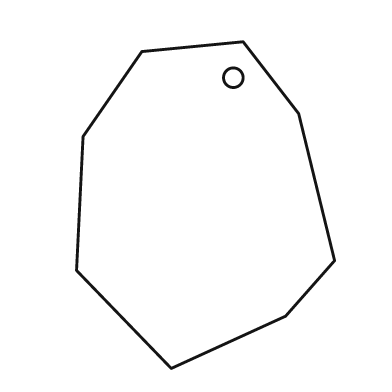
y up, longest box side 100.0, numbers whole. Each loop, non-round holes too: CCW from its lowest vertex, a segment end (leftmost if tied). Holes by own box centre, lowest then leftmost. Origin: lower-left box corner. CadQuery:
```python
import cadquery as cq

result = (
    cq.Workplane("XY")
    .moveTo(29.0, 0.0)
    .lineTo(64.0, 16.0)
    .lineTo(79.0, 33.0)
    .lineTo(68.0, 78.0)
    .lineTo(51.0, 100.0)
    .lineTo(20.0, 97.0)
    .lineTo(2.0, 71.0)
    .lineTo(0.0, 30.0)
    .close()
    .moveTo(48.0, 89.0)
    .circle(3.0)
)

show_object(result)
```